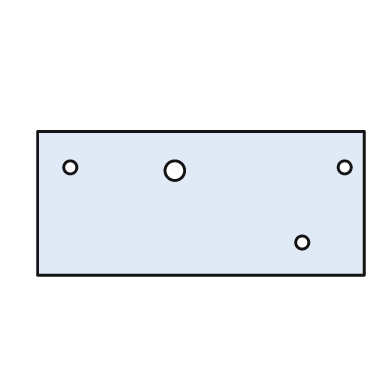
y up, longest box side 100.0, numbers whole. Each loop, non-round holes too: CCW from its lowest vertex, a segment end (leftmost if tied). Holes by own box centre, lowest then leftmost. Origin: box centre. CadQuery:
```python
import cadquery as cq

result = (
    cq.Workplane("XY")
    .moveTo(-50.0, -22.0)
    .lineTo(50.0, -22.0)
    .lineTo(50.0, 22.0)
    .lineTo(-50.0, 22.0)
    .close()
    .moveTo(31.0, -12.0)
    .circle(2.0)
    .moveTo(-8.0, 10.0)
    .circle(3.0)
    .moveTo(-40.0, 11.0)
    .circle(2.0)
    .moveTo(44.0, 11.0)
    .circle(2.0)
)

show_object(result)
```